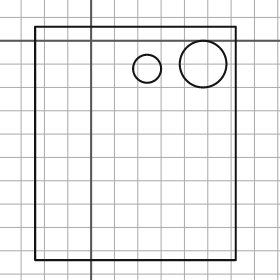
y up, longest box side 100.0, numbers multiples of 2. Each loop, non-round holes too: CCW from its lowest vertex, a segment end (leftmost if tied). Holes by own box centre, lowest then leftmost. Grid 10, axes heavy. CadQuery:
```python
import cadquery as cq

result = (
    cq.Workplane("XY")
    .moveTo(-24.0, -94.0)
    .lineTo(62.0, -94.0)
    .lineTo(62.0, 6.0)
    .lineTo(-24.0, 6.0)
    .close()
    .moveTo(24.0, -12.0)
    .circle(6.0)
    .moveTo(48.0, -10.0)
    .circle(10.0)
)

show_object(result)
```